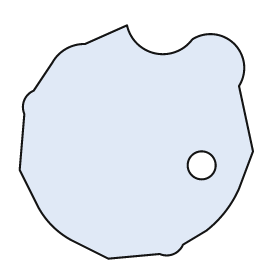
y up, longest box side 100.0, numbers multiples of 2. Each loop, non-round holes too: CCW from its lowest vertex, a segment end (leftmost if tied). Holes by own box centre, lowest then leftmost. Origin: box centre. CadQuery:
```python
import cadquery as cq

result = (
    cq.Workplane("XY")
    .moveTo(-12.0, -50.0)
    .lineTo(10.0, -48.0)
    .threePointArc((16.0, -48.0), (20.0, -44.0))
    .lineTo(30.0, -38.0)
    .threePointArc((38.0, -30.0), (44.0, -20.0))
    .lineTo(50.0, -4.0)
    .lineTo(44.0, 24.0)
    .threePointArc((42.0, 42.0), (24.0, 44.0))
    .threePointArc((8.0, 38.0), (-4.0, 50.0))
    .lineTo(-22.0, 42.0)
    .threePointArc((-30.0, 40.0), (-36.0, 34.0))
    .lineTo(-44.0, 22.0)
    .threePointArc((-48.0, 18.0), (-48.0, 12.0))
    .lineTo(-50.0, -12.0)
    .lineTo(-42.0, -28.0)
    .threePointArc((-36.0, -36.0), (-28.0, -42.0))
    .close()
    .moveTo(28.0, -10.0)
    .circle(6.0)
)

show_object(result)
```